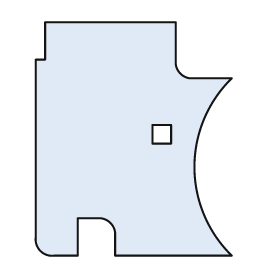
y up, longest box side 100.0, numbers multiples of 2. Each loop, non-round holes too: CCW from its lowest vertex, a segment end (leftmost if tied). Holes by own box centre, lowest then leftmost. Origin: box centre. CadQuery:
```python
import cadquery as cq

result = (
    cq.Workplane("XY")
    .moveTo(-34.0, -50.0)
    .lineTo(-24.0, -50.0)
    .lineTo(-24.0, -34.0)
    .lineTo(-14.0, -34.0)
    .threePointArc((-10.0, -36.0), (-8.0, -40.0))
    .lineTo(-8.0, -50.0)
    .lineTo(42.0, -50.0)
    .threePointArc((26.0, -12.0), (42.0, 26.0))
    .lineTo(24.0, 26.0)
    .threePointArc((20.0, 28.0), (18.0, 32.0))
    .lineTo(18.0, 50.0)
    .lineTo(-38.0, 50.0)
    .lineTo(-38.0, 34.0)
    .lineTo(-42.0, 34.0)
    .lineTo(-42.0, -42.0)
    .threePointArc((-40.0, -48.0), (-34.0, -50.0))
    .close()
    .moveTo(8.0, -2.0)
    .lineTo(16.0, -2.0)
    .lineTo(16.0, 6.0)
    .lineTo(8.0, 6.0)
    .close()
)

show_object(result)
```